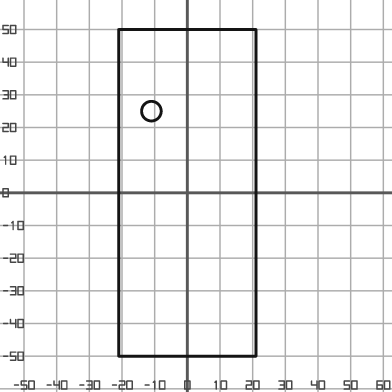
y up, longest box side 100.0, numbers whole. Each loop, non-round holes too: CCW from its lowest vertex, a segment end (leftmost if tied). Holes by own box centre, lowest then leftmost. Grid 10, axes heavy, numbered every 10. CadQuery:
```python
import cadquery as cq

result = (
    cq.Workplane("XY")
    .moveTo(-21.0, -50.0)
    .lineTo(21.0, -50.0)
    .lineTo(21.0, 50.0)
    .lineTo(-21.0, 50.0)
    .close()
    .moveTo(-11.0, 25.0)
    .circle(3.0)
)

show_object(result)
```